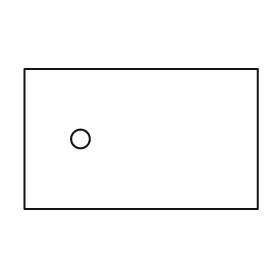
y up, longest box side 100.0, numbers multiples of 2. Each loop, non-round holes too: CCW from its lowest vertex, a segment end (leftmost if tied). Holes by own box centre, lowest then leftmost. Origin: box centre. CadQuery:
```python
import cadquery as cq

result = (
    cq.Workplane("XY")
    .moveTo(-50.0, -30.0)
    .lineTo(50.0, -30.0)
    .lineTo(50.0, 30.0)
    .lineTo(-50.0, 30.0)
    .close()
    .moveTo(-26.0, 0.0)
    .circle(4.0)
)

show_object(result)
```